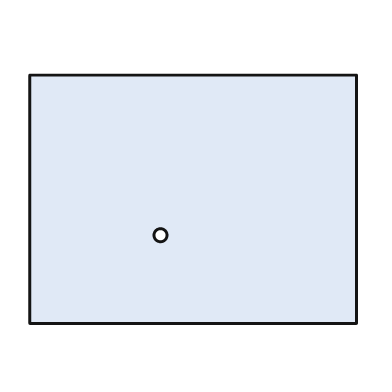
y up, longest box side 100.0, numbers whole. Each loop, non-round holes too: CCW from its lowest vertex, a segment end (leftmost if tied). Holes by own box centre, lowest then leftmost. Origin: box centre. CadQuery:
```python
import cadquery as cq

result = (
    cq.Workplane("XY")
    .moveTo(-50.0, -38.0)
    .lineTo(50.0, -38.0)
    .lineTo(50.0, 38.0)
    .lineTo(-50.0, 38.0)
    .close()
    .moveTo(-10.0, -11.0)
    .circle(2.0)
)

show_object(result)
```